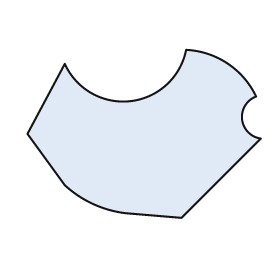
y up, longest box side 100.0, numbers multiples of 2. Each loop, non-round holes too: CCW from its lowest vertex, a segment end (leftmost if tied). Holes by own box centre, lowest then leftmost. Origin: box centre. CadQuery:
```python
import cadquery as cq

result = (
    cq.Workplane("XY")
    .moveTo(16.0, -36.0)
    .lineTo(50.0, -2.0)
    .threePointArc((42.0, 6.0), (48.0, 16.0))
    .threePointArc((36.0, 30.0), (18.0, 36.0))
    .threePointArc((-6.0, 14.0), (-34.0, 30.0))
    .lineTo(-50.0, 0.0)
    .lineTo(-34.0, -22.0)
    .threePointArc((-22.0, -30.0), (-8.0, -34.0))
    .close()
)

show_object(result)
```